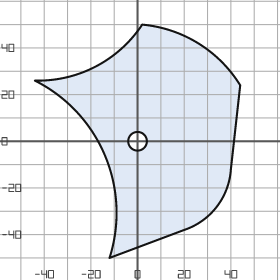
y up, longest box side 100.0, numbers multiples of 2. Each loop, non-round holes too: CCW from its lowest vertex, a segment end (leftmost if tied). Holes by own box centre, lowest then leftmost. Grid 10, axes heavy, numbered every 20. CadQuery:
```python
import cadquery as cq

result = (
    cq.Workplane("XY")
    .moveTo(-12.0, -50.0)
    .lineTo(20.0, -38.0)
    .threePointArc((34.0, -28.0), (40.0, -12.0))
    .lineTo(44.0, 24.0)
    .threePointArc((26.0, 42.0), (2.0, 50.0))
    .threePointArc((-18.0, 32.0), (-44.0, 26.0))
    .threePointArc((-14.0, -6.0), (-12.0, -50.0))
    .close()
    .moveTo(0.0, 0.0)
    .circle(4.0)
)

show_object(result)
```